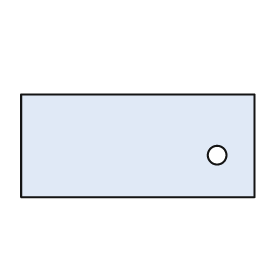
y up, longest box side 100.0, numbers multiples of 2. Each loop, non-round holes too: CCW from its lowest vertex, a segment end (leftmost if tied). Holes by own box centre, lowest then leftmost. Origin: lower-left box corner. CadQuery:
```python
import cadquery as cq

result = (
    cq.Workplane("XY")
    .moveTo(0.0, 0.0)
    .lineTo(100.0, 0.0)
    .lineTo(100.0, 44.0)
    .lineTo(0.0, 44.0)
    .close()
    .moveTo(84.0, 18.0)
    .circle(4.0)
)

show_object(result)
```